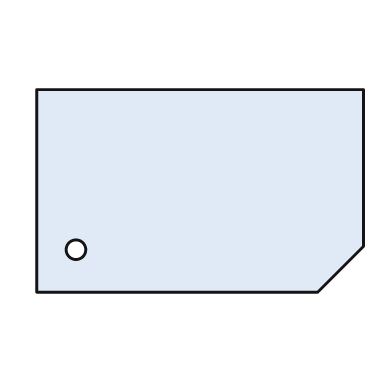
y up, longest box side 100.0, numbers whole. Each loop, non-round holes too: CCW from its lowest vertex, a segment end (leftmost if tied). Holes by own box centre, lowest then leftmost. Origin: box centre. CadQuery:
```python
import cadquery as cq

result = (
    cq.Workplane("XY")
    .moveTo(-50.0, -31.0)
    .lineTo(36.0, -31.0)
    .lineTo(50.0, -17.0)
    .lineTo(50.0, 31.0)
    .lineTo(-50.0, 31.0)
    .close()
    .moveTo(-38.0, -18.0)
    .circle(3.0)
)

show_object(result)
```